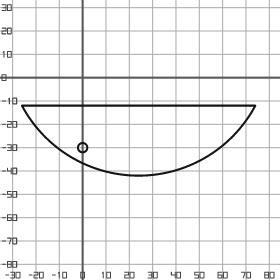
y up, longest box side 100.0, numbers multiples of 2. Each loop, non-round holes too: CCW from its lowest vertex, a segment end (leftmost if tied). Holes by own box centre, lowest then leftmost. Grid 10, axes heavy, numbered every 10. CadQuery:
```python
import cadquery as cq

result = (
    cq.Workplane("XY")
    .moveTo(-26.0, -12.0)
    .threePointArc((24.0, -42.0), (74.0, -12.0))
    .close()
    .moveTo(0.0, -30.0)
    .circle(2.0)
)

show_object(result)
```